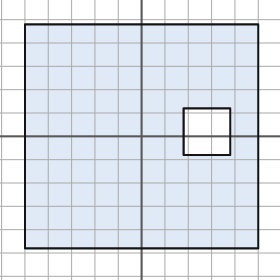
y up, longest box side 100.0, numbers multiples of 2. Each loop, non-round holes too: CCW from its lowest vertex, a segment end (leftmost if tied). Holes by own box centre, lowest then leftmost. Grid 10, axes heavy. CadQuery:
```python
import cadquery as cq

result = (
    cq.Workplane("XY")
    .moveTo(-50.0, -48.0)
    .lineTo(50.0, -48.0)
    .lineTo(50.0, 48.0)
    .lineTo(-50.0, 48.0)
    .close()
    .moveTo(18.0, -8.0)
    .lineTo(38.0, -8.0)
    .lineTo(38.0, 12.0)
    .lineTo(18.0, 12.0)
    .close()
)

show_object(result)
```